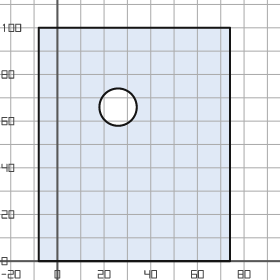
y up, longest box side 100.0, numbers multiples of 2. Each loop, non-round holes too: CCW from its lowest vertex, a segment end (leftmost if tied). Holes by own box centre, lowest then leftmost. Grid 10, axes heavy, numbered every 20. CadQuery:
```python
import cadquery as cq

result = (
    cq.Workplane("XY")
    .moveTo(-8.0, 0.0)
    .lineTo(74.0, 0.0)
    .lineTo(74.0, 100.0)
    .lineTo(-8.0, 100.0)
    .close()
    .moveTo(26.0, 66.0)
    .circle(8.0)
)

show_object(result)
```